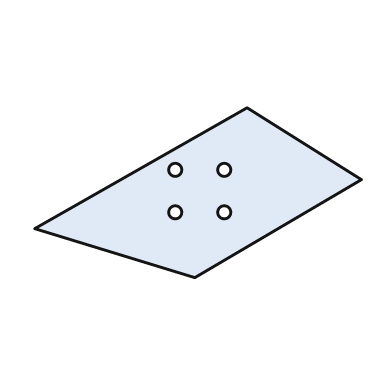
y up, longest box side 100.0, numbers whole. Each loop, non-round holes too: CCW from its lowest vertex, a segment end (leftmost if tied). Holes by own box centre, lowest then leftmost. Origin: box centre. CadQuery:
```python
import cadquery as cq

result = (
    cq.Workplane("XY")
    .moveTo(-1.0, -26.0)
    .lineTo(50.0, 4.0)
    .lineTo(15.0, 26.0)
    .lineTo(-50.0, -11.0)
    .close()
    .moveTo(-7.0, -6.0)
    .circle(2.0)
    .moveTo(8.0, -6.0)
    .circle(2.0)
    .moveTo(-7.0, 7.0)
    .circle(2.0)
    .moveTo(8.0, 7.0)
    .circle(2.0)
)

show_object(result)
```